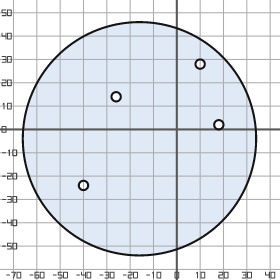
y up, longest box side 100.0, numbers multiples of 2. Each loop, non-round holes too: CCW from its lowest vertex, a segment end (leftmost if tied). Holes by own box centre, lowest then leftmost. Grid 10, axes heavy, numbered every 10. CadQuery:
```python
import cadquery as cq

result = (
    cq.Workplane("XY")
    .moveTo(-16.0, -4.0)
    .circle(50.0)
    .moveTo(-40.0, -24.0)
    .circle(2.0)
    .moveTo(18.0, 2.0)
    .circle(2.0)
    .moveTo(-26.0, 14.0)
    .circle(2.0)
    .moveTo(10.0, 28.0)
    .circle(2.0)
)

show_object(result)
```